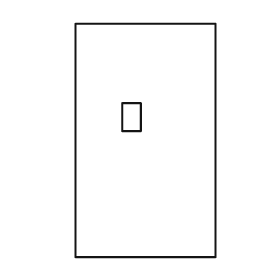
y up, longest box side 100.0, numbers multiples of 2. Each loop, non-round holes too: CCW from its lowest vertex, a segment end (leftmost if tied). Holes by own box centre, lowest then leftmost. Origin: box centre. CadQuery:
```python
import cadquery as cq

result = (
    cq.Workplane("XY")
    .moveTo(-30.0, -50.0)
    .lineTo(30.0, -50.0)
    .lineTo(30.0, 50.0)
    .lineTo(-30.0, 50.0)
    .close()
    .moveTo(-10.0, 4.0)
    .lineTo(-2.0, 4.0)
    .lineTo(-2.0, 16.0)
    .lineTo(-10.0, 16.0)
    .close()
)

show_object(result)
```